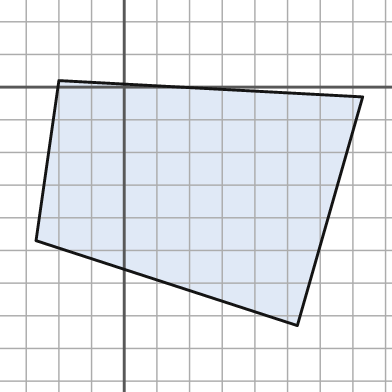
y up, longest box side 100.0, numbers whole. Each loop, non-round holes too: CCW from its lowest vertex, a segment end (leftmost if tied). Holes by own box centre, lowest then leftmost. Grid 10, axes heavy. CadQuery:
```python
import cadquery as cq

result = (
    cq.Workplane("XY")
    .moveTo(53.0, -73.0)
    .lineTo(73.0, -3.0)
    .lineTo(-20.0, 2.0)
    .lineTo(-27.0, -47.0)
    .close()
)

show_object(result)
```